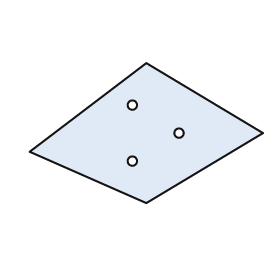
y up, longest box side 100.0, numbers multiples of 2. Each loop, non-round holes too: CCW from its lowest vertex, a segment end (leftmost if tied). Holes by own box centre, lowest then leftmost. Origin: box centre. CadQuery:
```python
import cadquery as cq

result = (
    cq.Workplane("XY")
    .moveTo(0.0, -30.0)
    .lineTo(50.0, 0.0)
    .lineTo(0.0, 30.0)
    .lineTo(-50.0, -8.0)
    .close()
    .moveTo(-6.0, -12.0)
    .circle(2.0)
    .moveTo(14.0, 0.0)
    .circle(2.0)
    .moveTo(-6.0, 12.0)
    .circle(2.0)
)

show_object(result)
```